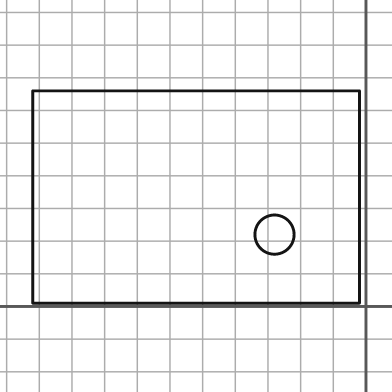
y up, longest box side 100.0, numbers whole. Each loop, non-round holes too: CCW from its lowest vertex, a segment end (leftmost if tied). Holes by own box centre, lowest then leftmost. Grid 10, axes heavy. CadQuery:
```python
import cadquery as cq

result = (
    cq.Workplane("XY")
    .moveTo(-102.0, 1.0)
    .lineTo(-2.0, 1.0)
    .lineTo(-2.0, 66.0)
    .lineTo(-102.0, 66.0)
    .close()
    .moveTo(-28.0, 22.0)
    .circle(6.0)
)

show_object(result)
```